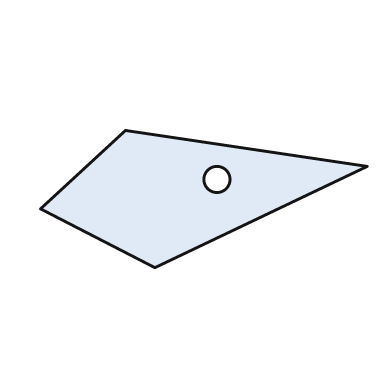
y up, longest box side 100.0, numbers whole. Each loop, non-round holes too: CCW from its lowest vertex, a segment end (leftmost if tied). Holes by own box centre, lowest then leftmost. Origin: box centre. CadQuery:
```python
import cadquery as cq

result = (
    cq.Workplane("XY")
    .moveTo(-15.0, -21.0)
    .lineTo(50.0, 10.0)
    .lineTo(-24.0, 21.0)
    .lineTo(-50.0, -3.0)
    .close()
    .moveTo(4.0, 6.0)
    .circle(4.0)
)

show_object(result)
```